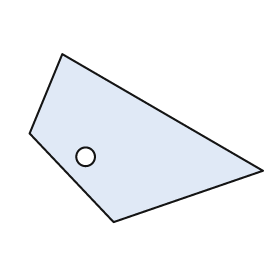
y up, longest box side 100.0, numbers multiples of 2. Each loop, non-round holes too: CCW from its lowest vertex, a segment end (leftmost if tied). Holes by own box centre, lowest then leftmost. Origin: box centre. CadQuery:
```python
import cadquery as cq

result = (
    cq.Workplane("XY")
    .moveTo(-14.0, -36.0)
    .lineTo(50.0, -14.0)
    .lineTo(-36.0, 36.0)
    .lineTo(-50.0, 2.0)
    .close()
    .moveTo(-26.0, -8.0)
    .circle(4.0)
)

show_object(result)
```